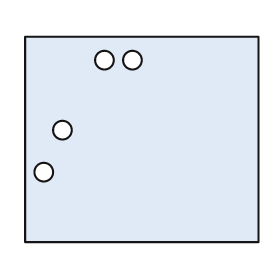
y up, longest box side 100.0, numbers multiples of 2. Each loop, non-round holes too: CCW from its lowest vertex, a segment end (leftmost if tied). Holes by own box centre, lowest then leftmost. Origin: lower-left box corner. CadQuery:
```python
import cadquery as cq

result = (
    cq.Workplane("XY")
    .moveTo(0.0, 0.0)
    .lineTo(100.0, 0.0)
    .lineTo(100.0, 88.0)
    .lineTo(0.0, 88.0)
    .close()
    .moveTo(8.0, 30.0)
    .circle(4.0)
    .moveTo(16.0, 48.0)
    .circle(4.0)
    .moveTo(34.0, 78.0)
    .circle(4.0)
    .moveTo(46.0, 78.0)
    .circle(4.0)
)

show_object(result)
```